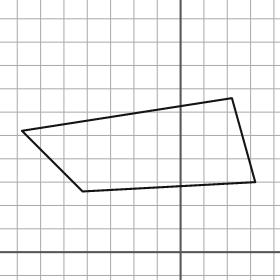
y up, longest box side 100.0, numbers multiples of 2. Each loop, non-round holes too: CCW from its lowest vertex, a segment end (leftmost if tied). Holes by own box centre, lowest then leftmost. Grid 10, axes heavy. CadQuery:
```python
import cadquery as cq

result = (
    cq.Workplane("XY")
    .moveTo(-42.0, 26.0)
    .lineTo(32.0, 30.0)
    .lineTo(22.0, 66.0)
    .lineTo(-68.0, 52.0)
    .close()
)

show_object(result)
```